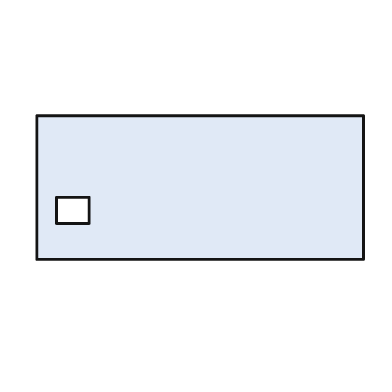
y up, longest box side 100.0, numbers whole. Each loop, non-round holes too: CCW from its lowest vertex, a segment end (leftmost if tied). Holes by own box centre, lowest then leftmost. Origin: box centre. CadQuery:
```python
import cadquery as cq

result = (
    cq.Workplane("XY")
    .moveTo(-50.0, -22.0)
    .lineTo(50.0, -22.0)
    .lineTo(50.0, 22.0)
    .lineTo(-50.0, 22.0)
    .close()
    .moveTo(-44.0, -11.0)
    .lineTo(-34.0, -11.0)
    .lineTo(-34.0, -3.0)
    .lineTo(-44.0, -3.0)
    .close()
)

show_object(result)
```